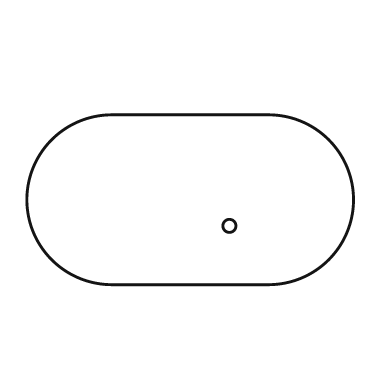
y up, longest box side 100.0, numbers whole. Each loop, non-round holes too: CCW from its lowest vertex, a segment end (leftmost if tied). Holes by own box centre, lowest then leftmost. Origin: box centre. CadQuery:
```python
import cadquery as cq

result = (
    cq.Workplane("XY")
    .moveTo(-24.0, -26.0)
    .lineTo(24.0, -26.0)
    .threePointArc((50.0, 0.0), (24.0, 26.0))
    .lineTo(-24.0, 26.0)
    .threePointArc((-50.0, 0.0), (-24.0, -26.0))
    .close()
    .moveTo(12.0, -8.0)
    .circle(2.0)
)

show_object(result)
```